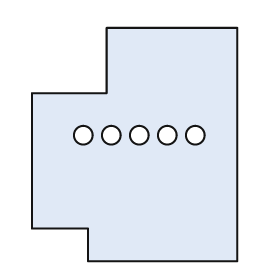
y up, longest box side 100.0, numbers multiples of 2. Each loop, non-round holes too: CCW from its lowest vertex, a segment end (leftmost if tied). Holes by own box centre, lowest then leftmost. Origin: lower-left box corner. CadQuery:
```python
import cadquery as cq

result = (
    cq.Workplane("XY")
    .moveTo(24.0, 0.0)
    .lineTo(88.0, 0.0)
    .lineTo(88.0, 100.0)
    .lineTo(32.0, 100.0)
    .lineTo(32.0, 72.0)
    .lineTo(0.0, 72.0)
    .lineTo(0.0, 14.0)
    .lineTo(24.0, 14.0)
    .close()
    .moveTo(22.0, 54.0)
    .circle(4.0)
    .moveTo(34.0, 54.0)
    .circle(4.0)
    .moveTo(46.0, 54.0)
    .circle(4.0)
    .moveTo(58.0, 54.0)
    .circle(4.0)
    .moveTo(70.0, 54.0)
    .circle(4.0)
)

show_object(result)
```